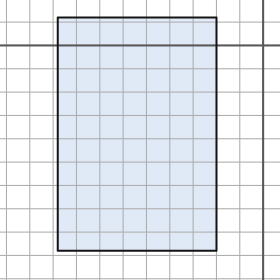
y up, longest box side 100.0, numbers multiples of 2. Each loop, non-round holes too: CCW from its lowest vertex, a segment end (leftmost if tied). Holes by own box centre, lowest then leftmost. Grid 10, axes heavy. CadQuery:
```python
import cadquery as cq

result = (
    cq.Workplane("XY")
    .moveTo(-88.0, -88.0)
    .lineTo(-20.0, -88.0)
    .lineTo(-20.0, 12.0)
    .lineTo(-88.0, 12.0)
    .close()
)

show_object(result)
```